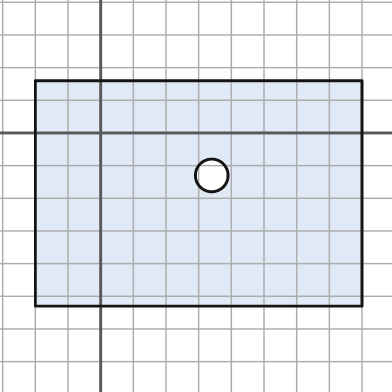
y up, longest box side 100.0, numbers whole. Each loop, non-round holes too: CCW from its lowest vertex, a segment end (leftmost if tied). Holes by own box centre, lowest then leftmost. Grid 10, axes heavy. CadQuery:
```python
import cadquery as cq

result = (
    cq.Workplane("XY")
    .moveTo(-20.0, -53.0)
    .lineTo(80.0, -53.0)
    .lineTo(80.0, 16.0)
    .lineTo(-20.0, 16.0)
    .close()
    .moveTo(34.0, -13.0)
    .circle(5.0)
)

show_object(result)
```